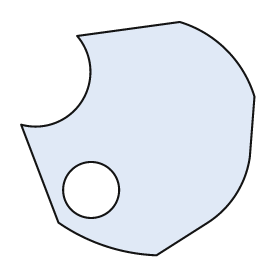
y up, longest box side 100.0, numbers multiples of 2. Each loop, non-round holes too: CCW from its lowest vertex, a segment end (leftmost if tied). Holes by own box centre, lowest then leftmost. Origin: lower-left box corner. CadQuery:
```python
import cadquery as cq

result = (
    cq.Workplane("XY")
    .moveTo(58.0, 0.0)
    .lineTo(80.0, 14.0)
    .threePointArc((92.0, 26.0), (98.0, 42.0))
    .lineTo(100.0, 68.0)
    .threePointArc((88.0, 88.0), (68.0, 100.0))
    .lineTo(24.0, 94.0)
    .threePointArc((26.0, 66.0), (0.0, 56.0))
    .lineTo(16.0, 14.0)
    .threePointArc((36.0, 4.0), (58.0, 0.0))
    .close()
    .moveTo(30.0, 28.0)
    .circle(12.0)
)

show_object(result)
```